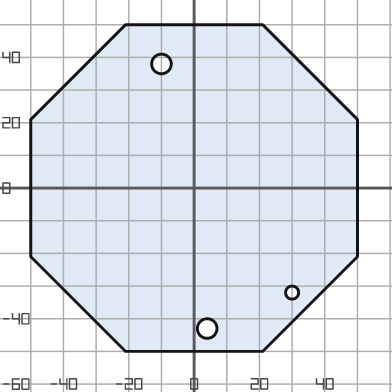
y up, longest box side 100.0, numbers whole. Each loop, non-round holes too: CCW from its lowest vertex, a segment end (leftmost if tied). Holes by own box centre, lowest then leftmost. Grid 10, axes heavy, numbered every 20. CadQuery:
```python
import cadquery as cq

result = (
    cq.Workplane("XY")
    .moveTo(-21.0, -50.0)
    .lineTo(21.0, -50.0)
    .lineTo(50.0, -21.0)
    .lineTo(50.0, 21.0)
    .lineTo(21.0, 50.0)
    .lineTo(-21.0, 50.0)
    .lineTo(-50.0, 21.0)
    .lineTo(-50.0, -21.0)
    .close()
    .moveTo(4.0, -43.0)
    .circle(3.0)
    .moveTo(30.0, -32.0)
    .circle(2.0)
    .moveTo(-10.0, 38.0)
    .circle(3.0)
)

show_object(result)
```